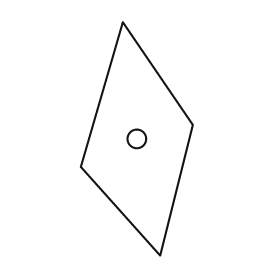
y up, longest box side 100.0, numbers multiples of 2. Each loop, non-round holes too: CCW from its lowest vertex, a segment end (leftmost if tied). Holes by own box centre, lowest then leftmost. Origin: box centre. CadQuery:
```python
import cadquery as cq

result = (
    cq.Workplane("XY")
    .moveTo(10.0, -50.0)
    .lineTo(24.0, 6.0)
    .lineTo(-6.0, 50.0)
    .lineTo(-24.0, -12.0)
    .close()
    .moveTo(0.0, 0.0)
    .circle(4.0)
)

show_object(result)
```